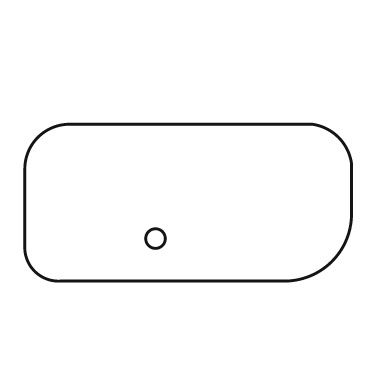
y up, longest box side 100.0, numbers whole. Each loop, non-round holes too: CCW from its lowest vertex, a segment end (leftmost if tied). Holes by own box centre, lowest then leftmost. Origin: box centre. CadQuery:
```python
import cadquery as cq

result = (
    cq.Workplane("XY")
    .moveTo(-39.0, -24.0)
    .lineTo(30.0, -24.0)
    .threePointArc((44.0, -18.0), (50.0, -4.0))
    .lineTo(50.0, 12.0)
    .threePointArc((46.0, 20.0), (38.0, 24.0))
    .lineTo(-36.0, 24.0)
    .threePointArc((-46.0, 20.0), (-50.0, 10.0))
    .lineTo(-50.0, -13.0)
    .threePointArc((-47.0, -21.0), (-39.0, -24.0))
    .close()
    .moveTo(-10.0, -11.0)
    .circle(3.0)
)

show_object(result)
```